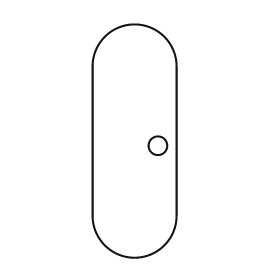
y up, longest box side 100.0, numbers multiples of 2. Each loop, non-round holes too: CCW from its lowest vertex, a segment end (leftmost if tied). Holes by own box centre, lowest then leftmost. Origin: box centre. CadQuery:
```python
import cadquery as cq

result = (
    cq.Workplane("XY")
    .moveTo(-18.0, -32.0)
    .threePointArc((0.0, -50.0), (18.0, -32.0))
    .lineTo(18.0, 32.0)
    .threePointArc((0.0, 50.0), (-18.0, 32.0))
    .close()
    .moveTo(10.0, -2.0)
    .circle(4.0)
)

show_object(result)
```